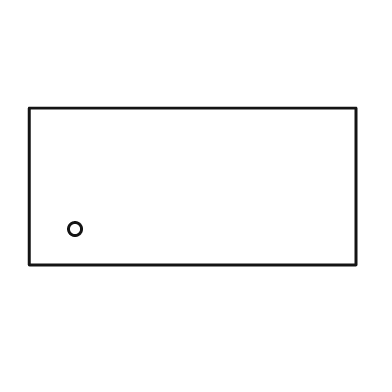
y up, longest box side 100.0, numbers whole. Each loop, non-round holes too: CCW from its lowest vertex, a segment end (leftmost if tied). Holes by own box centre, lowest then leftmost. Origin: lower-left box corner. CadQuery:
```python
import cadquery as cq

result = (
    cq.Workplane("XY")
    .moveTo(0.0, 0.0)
    .lineTo(100.0, 0.0)
    .lineTo(100.0, 48.0)
    .lineTo(0.0, 48.0)
    .close()
    .moveTo(14.0, 11.0)
    .circle(2.0)
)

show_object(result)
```